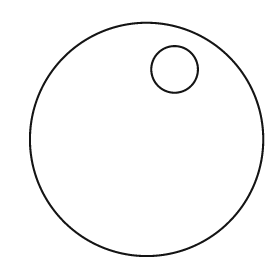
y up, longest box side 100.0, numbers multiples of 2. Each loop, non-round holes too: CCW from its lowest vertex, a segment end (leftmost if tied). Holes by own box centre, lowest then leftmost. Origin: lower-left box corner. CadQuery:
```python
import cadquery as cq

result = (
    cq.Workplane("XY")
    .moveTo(50.0, 50.0)
    .circle(50.0)
    .moveTo(62.0, 80.0)
    .circle(10.0)
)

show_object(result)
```